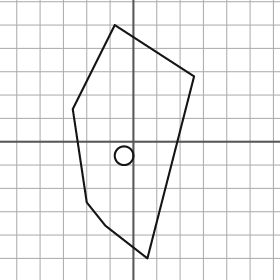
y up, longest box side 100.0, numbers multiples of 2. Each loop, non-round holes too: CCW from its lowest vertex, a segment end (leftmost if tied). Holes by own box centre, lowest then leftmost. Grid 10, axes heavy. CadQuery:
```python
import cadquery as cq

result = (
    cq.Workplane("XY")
    .moveTo(6.0, -50.0)
    .lineTo(26.0, 28.0)
    .lineTo(-8.0, 50.0)
    .lineTo(-26.0, 14.0)
    .lineTo(-20.0, -26.0)
    .lineTo(-12.0, -36.0)
    .close()
    .moveTo(-4.0, -6.0)
    .circle(4.0)
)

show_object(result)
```